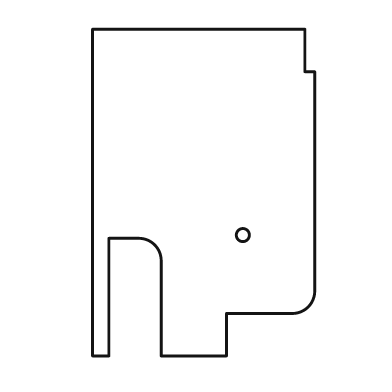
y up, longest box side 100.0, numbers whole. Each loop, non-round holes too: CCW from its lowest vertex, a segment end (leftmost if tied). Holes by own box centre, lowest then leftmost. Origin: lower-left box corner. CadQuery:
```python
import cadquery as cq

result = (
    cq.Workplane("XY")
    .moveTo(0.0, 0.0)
    .lineTo(5.0, 0.0)
    .lineTo(5.0, 36.0)
    .lineTo(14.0, 36.0)
    .threePointArc((19.0, 34.0), (21.0, 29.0))
    .lineTo(21.0, 0.0)
    .lineTo(41.0, 0.0)
    .lineTo(41.0, 13.0)
    .lineTo(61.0, 13.0)
    .threePointArc((66.0, 15.0), (68.0, 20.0))
    .lineTo(68.0, 87.0)
    .lineTo(65.0, 87.0)
    .lineTo(65.0, 100.0)
    .lineTo(0.0, 100.0)
    .close()
    .moveTo(46.0, 37.0)
    .circle(2.0)
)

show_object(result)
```